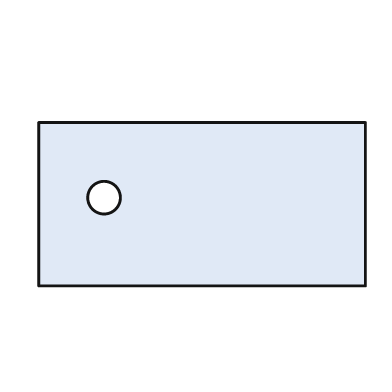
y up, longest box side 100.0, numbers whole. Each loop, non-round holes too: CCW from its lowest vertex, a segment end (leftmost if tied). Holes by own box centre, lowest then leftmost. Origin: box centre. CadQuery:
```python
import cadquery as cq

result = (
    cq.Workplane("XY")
    .moveTo(-50.0, -25.0)
    .lineTo(50.0, -25.0)
    .lineTo(50.0, 25.0)
    .lineTo(-50.0, 25.0)
    .close()
    .moveTo(-30.0, 2.0)
    .circle(5.0)
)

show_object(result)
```